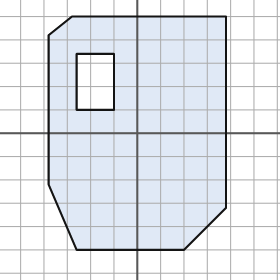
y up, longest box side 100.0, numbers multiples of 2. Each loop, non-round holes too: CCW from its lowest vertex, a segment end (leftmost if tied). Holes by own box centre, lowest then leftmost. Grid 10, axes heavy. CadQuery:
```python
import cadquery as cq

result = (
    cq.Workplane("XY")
    .moveTo(-26.0, -50.0)
    .lineTo(20.0, -50.0)
    .lineTo(38.0, -32.0)
    .lineTo(38.0, 50.0)
    .lineTo(-28.0, 50.0)
    .lineTo(-38.0, 42.0)
    .lineTo(-38.0, -22.0)
    .close()
    .moveTo(-26.0, 10.0)
    .lineTo(-10.0, 10.0)
    .lineTo(-10.0, 34.0)
    .lineTo(-26.0, 34.0)
    .close()
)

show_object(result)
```